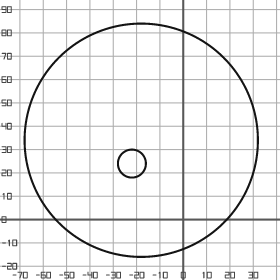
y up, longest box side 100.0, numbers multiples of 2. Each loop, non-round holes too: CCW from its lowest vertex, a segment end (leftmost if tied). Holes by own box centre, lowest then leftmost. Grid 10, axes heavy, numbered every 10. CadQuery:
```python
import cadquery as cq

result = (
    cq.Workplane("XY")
    .moveTo(-18.0, 34.0)
    .circle(50.0)
    .moveTo(-22.0, 24.0)
    .circle(6.0)
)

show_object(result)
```